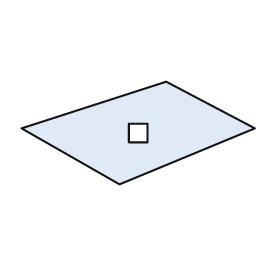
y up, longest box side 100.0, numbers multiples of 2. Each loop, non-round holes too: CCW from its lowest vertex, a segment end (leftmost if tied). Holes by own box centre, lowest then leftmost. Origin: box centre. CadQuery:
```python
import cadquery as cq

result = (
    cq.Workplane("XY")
    .moveTo(-8.0, -22.0)
    .lineTo(50.0, 2.0)
    .lineTo(12.0, 22.0)
    .lineTo(-50.0, 2.0)
    .close()
    .moveTo(-4.0, -4.0)
    .lineTo(4.0, -4.0)
    .lineTo(4.0, 4.0)
    .lineTo(-4.0, 4.0)
    .close()
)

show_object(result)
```